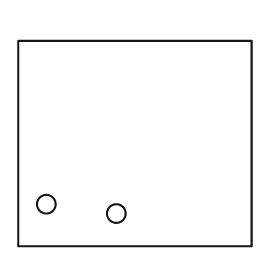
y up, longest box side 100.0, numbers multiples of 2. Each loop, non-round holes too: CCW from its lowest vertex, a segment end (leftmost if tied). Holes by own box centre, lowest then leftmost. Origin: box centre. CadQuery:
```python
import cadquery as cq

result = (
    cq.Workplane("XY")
    .moveTo(-50.0, -44.0)
    .lineTo(50.0, -44.0)
    .lineTo(50.0, 44.0)
    .lineTo(-50.0, 44.0)
    .close()
    .moveTo(-8.0, -30.0)
    .circle(4.0)
    .moveTo(-38.0, -26.0)
    .circle(4.0)
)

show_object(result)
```